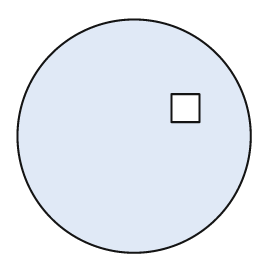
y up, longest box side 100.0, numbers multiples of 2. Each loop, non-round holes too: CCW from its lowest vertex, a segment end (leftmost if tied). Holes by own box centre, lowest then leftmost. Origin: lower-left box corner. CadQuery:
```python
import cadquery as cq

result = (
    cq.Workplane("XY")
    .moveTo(50.0, 50.0)
    .circle(50.0)
    .moveTo(66.0, 56.0)
    .lineTo(78.0, 56.0)
    .lineTo(78.0, 68.0)
    .lineTo(66.0, 68.0)
    .close()
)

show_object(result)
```